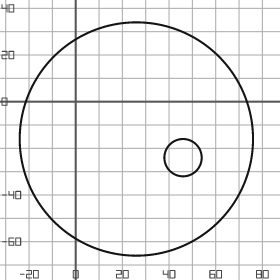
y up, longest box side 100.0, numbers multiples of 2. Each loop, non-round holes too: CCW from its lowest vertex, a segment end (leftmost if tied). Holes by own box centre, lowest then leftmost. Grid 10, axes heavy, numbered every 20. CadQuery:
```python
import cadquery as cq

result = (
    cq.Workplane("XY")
    .moveTo(26.0, -16.0)
    .circle(50.0)
    .moveTo(46.0, -24.0)
    .circle(8.0)
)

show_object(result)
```